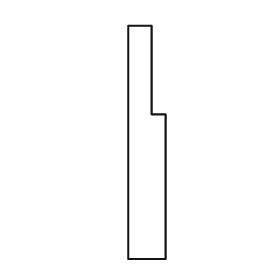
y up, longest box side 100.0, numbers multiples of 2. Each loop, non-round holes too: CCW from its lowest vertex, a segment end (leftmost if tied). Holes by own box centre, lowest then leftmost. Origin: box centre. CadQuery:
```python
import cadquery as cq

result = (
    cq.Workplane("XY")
    .moveTo(-8.0, -50.0)
    .lineTo(8.0, -50.0)
    .lineTo(8.0, 12.0)
    .lineTo(2.0, 12.0)
    .lineTo(2.0, 50.0)
    .lineTo(-8.0, 50.0)
    .close()
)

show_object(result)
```